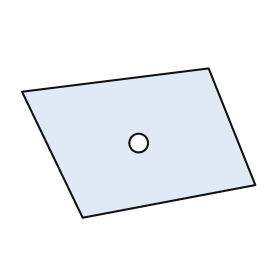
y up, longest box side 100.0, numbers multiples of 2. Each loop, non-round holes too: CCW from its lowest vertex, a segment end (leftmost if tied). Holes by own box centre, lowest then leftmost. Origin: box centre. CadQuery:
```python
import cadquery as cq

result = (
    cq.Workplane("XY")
    .moveTo(-24.0, -32.0)
    .lineTo(50.0, -18.0)
    .lineTo(30.0, 32.0)
    .lineTo(-50.0, 22.0)
    .close()
    .moveTo(0.0, 0.0)
    .circle(4.0)
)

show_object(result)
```